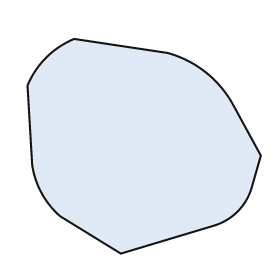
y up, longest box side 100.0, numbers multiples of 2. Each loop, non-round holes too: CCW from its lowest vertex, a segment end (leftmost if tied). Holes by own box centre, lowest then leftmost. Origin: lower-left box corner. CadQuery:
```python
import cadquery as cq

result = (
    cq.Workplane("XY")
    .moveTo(40.0, 0.0)
    .lineTo(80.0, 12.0)
    .threePointArc((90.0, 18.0), (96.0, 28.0))
    .lineTo(100.0, 42.0)
    .lineTo(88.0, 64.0)
    .threePointArc((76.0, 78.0), (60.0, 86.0))
    .lineTo(20.0, 92.0)
    .threePointArc((8.0, 84.0), (0.0, 72.0))
    .lineTo(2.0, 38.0)
    .threePointArc((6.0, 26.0), (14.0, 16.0))
    .close()
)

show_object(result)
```